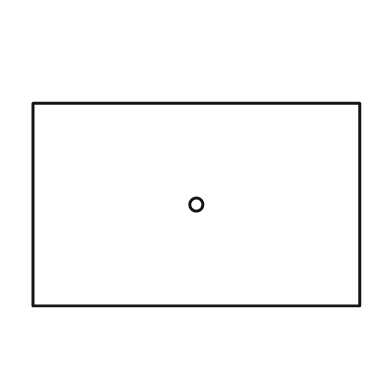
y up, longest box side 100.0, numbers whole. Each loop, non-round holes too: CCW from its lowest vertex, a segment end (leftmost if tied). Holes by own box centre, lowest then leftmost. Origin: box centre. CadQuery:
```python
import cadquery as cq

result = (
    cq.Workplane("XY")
    .moveTo(-50.0, -31.0)
    .lineTo(50.0, -31.0)
    .lineTo(50.0, 31.0)
    .lineTo(-50.0, 31.0)
    .close()
    .moveTo(0.0, 0.0)
    .circle(2.0)
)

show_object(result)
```